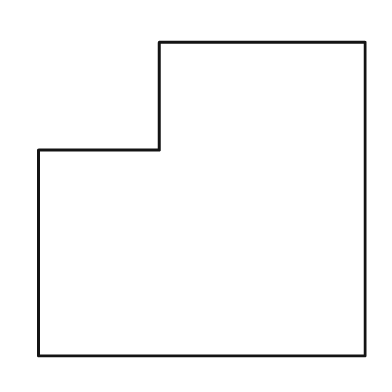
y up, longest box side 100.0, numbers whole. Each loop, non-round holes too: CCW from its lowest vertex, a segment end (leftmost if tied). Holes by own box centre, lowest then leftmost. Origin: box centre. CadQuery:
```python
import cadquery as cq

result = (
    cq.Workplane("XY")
    .moveTo(-50.0, -48.0)
    .lineTo(50.0, -48.0)
    .lineTo(50.0, 48.0)
    .lineTo(-13.0, 48.0)
    .lineTo(-13.0, 15.0)
    .lineTo(-50.0, 15.0)
    .close()
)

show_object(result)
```